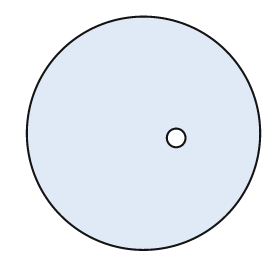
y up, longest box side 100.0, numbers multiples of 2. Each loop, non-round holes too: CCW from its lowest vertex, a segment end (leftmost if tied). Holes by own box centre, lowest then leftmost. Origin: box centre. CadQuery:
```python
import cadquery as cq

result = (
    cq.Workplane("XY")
    .moveTo(0.0, 0.0)
    .circle(50.0)
    .moveTo(14.0, -2.0)
    .circle(4.0)
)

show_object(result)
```